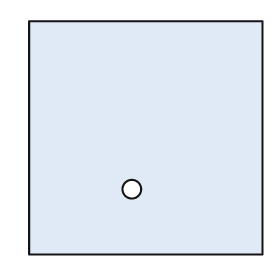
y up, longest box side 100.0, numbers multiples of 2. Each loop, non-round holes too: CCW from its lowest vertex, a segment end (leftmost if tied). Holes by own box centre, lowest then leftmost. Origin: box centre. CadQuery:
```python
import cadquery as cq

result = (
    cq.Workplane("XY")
    .moveTo(-50.0, -50.0)
    .lineTo(50.0, -50.0)
    .lineTo(50.0, 50.0)
    .lineTo(-50.0, 50.0)
    .close()
    .moveTo(-6.0, -22.0)
    .circle(4.0)
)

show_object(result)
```